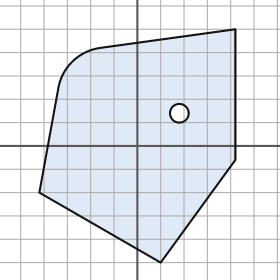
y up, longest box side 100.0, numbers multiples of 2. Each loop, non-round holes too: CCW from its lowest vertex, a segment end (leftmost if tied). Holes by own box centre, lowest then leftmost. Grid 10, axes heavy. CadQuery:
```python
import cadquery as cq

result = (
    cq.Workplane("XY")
    .moveTo(10.0, -50.0)
    .lineTo(42.0, -6.0)
    .lineTo(42.0, 50.0)
    .lineTo(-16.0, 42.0)
    .threePointArc((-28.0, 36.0), (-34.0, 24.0))
    .lineTo(-42.0, -20.0)
    .close()
    .moveTo(18.0, 14.0)
    .circle(4.0)
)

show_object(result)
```